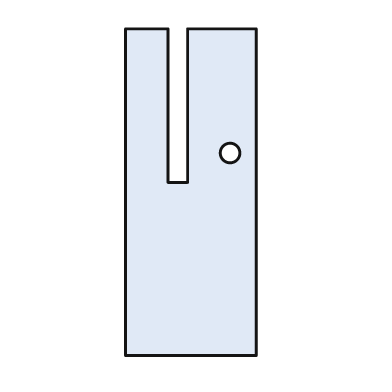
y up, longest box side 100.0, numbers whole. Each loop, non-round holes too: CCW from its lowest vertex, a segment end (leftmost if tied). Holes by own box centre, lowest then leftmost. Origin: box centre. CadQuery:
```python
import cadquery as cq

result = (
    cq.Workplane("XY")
    .moveTo(-20.0, -50.0)
    .lineTo(20.0, -50.0)
    .lineTo(20.0, 50.0)
    .lineTo(-1.0, 50.0)
    .lineTo(-1.0, 3.0)
    .lineTo(-7.0, 3.0)
    .lineTo(-7.0, 50.0)
    .lineTo(-20.0, 50.0)
    .close()
    .moveTo(12.0, 12.0)
    .circle(3.0)
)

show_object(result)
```